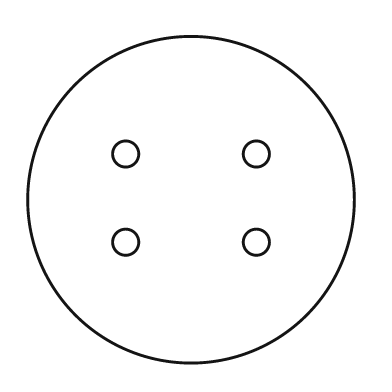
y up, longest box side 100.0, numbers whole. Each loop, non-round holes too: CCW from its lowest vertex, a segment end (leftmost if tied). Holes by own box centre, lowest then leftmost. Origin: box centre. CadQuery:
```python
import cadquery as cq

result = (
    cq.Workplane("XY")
    .moveTo(0.0, 0.0)
    .circle(50.0)
    .moveTo(-20.0, -13.0)
    .circle(4.0)
    .moveTo(20.0, -13.0)
    .circle(4.0)
    .moveTo(-20.0, 14.0)
    .circle(4.0)
    .moveTo(20.0, 14.0)
    .circle(4.0)
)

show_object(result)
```